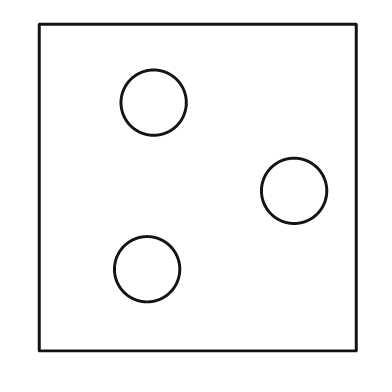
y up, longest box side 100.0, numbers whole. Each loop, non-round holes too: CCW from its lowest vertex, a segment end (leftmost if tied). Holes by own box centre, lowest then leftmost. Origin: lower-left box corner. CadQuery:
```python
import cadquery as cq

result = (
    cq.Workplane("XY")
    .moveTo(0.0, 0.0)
    .lineTo(97.0, 0.0)
    .lineTo(97.0, 100.0)
    .lineTo(0.0, 100.0)
    .close()
    .moveTo(33.0, 25.0)
    .circle(10.0)
    .moveTo(78.0, 49.0)
    .circle(10.0)
    .moveTo(35.0, 76.0)
    .circle(10.0)
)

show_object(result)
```